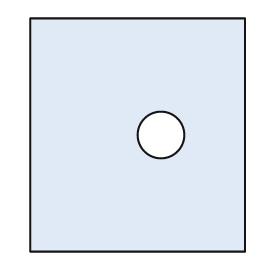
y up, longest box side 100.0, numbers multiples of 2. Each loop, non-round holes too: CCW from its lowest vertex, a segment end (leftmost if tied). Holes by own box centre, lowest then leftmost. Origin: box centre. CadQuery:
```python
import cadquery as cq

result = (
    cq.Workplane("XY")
    .moveTo(-46.0, -50.0)
    .lineTo(46.0, -50.0)
    .lineTo(46.0, 50.0)
    .lineTo(-46.0, 50.0)
    .close()
    .moveTo(10.0, 0.0)
    .circle(10.0)
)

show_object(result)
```